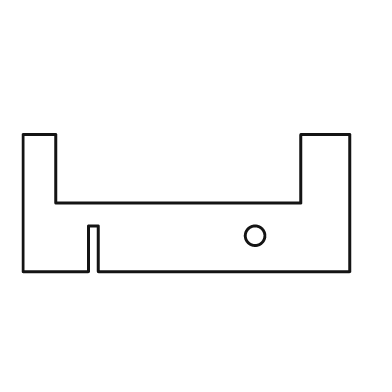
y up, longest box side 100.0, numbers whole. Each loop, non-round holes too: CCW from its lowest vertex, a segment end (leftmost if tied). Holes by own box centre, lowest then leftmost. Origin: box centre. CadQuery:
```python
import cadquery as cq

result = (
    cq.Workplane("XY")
    .moveTo(-50.0, -21.0)
    .lineTo(-30.0, -21.0)
    .lineTo(-30.0, -7.0)
    .lineTo(-27.0, -7.0)
    .lineTo(-27.0, -21.0)
    .lineTo(50.0, -21.0)
    .lineTo(50.0, 21.0)
    .lineTo(35.0, 21.0)
    .lineTo(35.0, 0.0)
    .lineTo(-40.0, 0.0)
    .lineTo(-40.0, 21.0)
    .lineTo(-50.0, 21.0)
    .close()
    .moveTo(21.0, -10.0)
    .circle(3.0)
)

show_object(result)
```